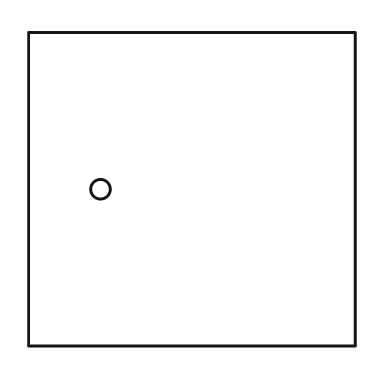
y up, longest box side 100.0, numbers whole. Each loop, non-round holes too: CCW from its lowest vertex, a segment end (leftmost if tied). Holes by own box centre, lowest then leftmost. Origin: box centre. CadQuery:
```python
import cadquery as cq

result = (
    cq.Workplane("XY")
    .moveTo(-50.0, -48.0)
    .lineTo(50.0, -48.0)
    .lineTo(50.0, 48.0)
    .lineTo(-50.0, 48.0)
    .close()
    .moveTo(-28.0, 0.0)
    .circle(3.0)
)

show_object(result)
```